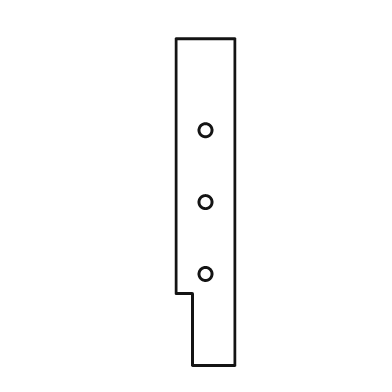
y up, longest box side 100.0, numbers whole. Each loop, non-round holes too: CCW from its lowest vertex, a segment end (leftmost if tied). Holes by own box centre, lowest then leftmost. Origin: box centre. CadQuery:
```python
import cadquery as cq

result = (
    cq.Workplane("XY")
    .moveTo(-4.0, -50.0)
    .lineTo(9.0, -50.0)
    .lineTo(9.0, 50.0)
    .lineTo(-9.0, 50.0)
    .lineTo(-9.0, -28.0)
    .lineTo(-4.0, -28.0)
    .close()
    .moveTo(0.0, -22.0)
    .circle(2.0)
    .moveTo(0.0, 0.0)
    .circle(2.0)
    .moveTo(0.0, 22.0)
    .circle(2.0)
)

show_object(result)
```